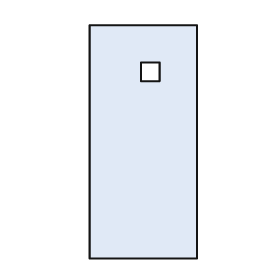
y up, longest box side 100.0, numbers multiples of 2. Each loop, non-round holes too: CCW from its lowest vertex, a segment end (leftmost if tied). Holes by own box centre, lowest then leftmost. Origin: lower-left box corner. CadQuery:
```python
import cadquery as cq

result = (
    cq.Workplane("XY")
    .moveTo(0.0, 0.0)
    .lineTo(46.0, 0.0)
    .lineTo(46.0, 100.0)
    .lineTo(0.0, 100.0)
    .close()
    .moveTo(22.0, 76.0)
    .lineTo(30.0, 76.0)
    .lineTo(30.0, 84.0)
    .lineTo(22.0, 84.0)
    .close()
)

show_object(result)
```